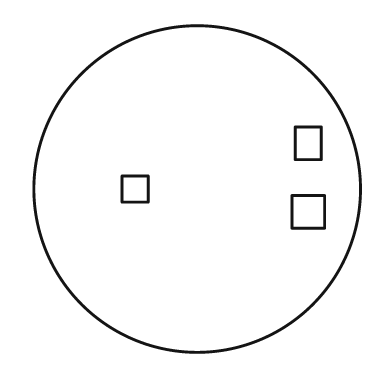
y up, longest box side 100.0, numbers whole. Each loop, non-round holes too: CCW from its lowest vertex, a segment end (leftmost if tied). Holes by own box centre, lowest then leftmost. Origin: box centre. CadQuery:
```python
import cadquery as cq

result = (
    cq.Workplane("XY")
    .moveTo(0.0, 0.0)
    .circle(50.0)
    .moveTo(29.0, -12.0)
    .lineTo(39.0, -12.0)
    .lineTo(39.0, -2.0)
    .lineTo(29.0, -2.0)
    .close()
    .moveTo(-23.0, -4.0)
    .lineTo(-15.0, -4.0)
    .lineTo(-15.0, 4.0)
    .lineTo(-23.0, 4.0)
    .close()
    .moveTo(30.0, 9.0)
    .lineTo(38.0, 9.0)
    .lineTo(38.0, 19.0)
    .lineTo(30.0, 19.0)
    .close()
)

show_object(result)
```